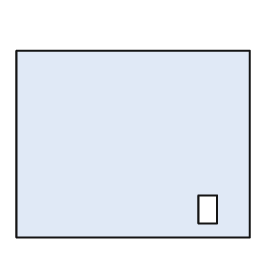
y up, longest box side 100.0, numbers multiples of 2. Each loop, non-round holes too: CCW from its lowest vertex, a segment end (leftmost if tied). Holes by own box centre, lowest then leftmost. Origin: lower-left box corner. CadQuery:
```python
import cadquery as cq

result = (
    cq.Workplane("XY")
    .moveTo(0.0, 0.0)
    .lineTo(100.0, 0.0)
    .lineTo(100.0, 80.0)
    .lineTo(0.0, 80.0)
    .close()
    .moveTo(78.0, 6.0)
    .lineTo(86.0, 6.0)
    .lineTo(86.0, 18.0)
    .lineTo(78.0, 18.0)
    .close()
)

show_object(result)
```